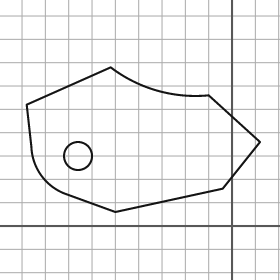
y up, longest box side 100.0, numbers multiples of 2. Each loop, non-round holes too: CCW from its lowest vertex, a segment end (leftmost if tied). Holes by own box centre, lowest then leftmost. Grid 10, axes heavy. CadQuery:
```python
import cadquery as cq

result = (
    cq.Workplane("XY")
    .moveTo(-50.0, 6.0)
    .lineTo(-4.0, 16.0)
    .lineTo(12.0, 36.0)
    .lineTo(-10.0, 56.0)
    .threePointArc((-32.0, 58.0), (-52.0, 68.0))
    .lineTo(-88.0, 52.0)
    .lineTo(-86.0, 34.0)
    .threePointArc((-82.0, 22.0), (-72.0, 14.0))
    .close()
    .moveTo(-66.0, 30.0)
    .circle(6.0)
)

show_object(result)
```